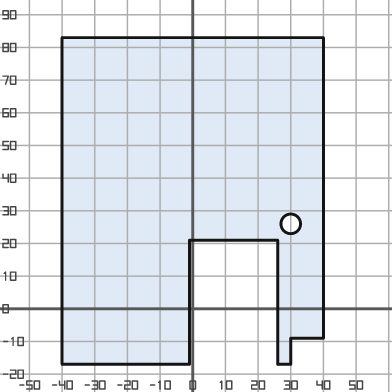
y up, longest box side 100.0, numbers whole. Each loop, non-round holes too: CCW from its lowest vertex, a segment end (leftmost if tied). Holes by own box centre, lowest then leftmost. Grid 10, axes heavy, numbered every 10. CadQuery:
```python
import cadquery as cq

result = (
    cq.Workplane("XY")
    .moveTo(-40.0, -17.0)
    .lineTo(-1.0, -17.0)
    .lineTo(-1.0, 21.0)
    .lineTo(26.0, 21.0)
    .lineTo(26.0, -17.0)
    .lineTo(30.0, -17.0)
    .lineTo(30.0, -9.0)
    .lineTo(40.0, -9.0)
    .lineTo(40.0, 83.0)
    .lineTo(-40.0, 83.0)
    .close()
    .moveTo(30.0, 26.0)
    .circle(3.0)
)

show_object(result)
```